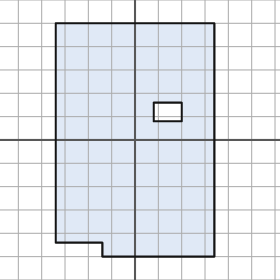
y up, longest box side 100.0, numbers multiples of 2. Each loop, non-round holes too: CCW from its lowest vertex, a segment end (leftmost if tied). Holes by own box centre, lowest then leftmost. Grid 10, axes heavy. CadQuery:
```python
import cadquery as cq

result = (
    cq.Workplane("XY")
    .moveTo(-14.0, -50.0)
    .lineTo(34.0, -50.0)
    .lineTo(34.0, 50.0)
    .lineTo(-34.0, 50.0)
    .lineTo(-34.0, -44.0)
    .lineTo(-14.0, -44.0)
    .close()
    .moveTo(8.0, 8.0)
    .lineTo(20.0, 8.0)
    .lineTo(20.0, 16.0)
    .lineTo(8.0, 16.0)
    .close()
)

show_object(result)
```